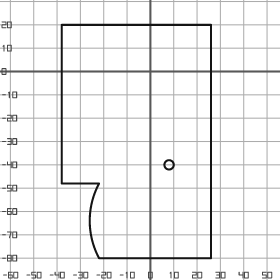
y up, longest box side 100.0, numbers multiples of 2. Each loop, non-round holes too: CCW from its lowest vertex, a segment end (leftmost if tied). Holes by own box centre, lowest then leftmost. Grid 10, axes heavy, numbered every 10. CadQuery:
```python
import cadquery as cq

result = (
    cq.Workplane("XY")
    .moveTo(-22.0, -80.0)
    .lineTo(26.0, -80.0)
    .lineTo(26.0, 20.0)
    .lineTo(-38.0, 20.0)
    .lineTo(-38.0, -48.0)
    .lineTo(-22.0, -48.0)
    .threePointArc((-26.0, -64.0), (-22.0, -80.0))
    .close()
    .moveTo(8.0, -40.0)
    .circle(2.0)
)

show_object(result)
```